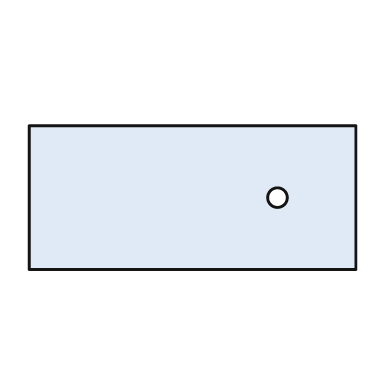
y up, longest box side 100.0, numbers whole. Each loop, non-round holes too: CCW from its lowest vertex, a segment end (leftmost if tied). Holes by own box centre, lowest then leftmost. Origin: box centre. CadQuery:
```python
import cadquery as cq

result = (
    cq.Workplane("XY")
    .moveTo(-50.0, -22.0)
    .lineTo(50.0, -22.0)
    .lineTo(50.0, 22.0)
    .lineTo(-50.0, 22.0)
    .close()
    .moveTo(26.0, 0.0)
    .circle(3.0)
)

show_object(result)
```